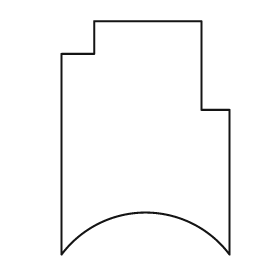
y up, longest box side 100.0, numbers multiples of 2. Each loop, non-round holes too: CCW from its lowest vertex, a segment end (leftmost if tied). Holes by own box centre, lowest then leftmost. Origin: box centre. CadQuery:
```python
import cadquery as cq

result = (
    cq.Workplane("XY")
    .moveTo(-36.0, -50.0)
    .threePointArc((0.0, -32.0), (36.0, -50.0))
    .lineTo(36.0, 12.0)
    .lineTo(24.0, 12.0)
    .lineTo(24.0, 50.0)
    .lineTo(-22.0, 50.0)
    .lineTo(-22.0, 36.0)
    .lineTo(-36.0, 36.0)
    .close()
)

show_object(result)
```